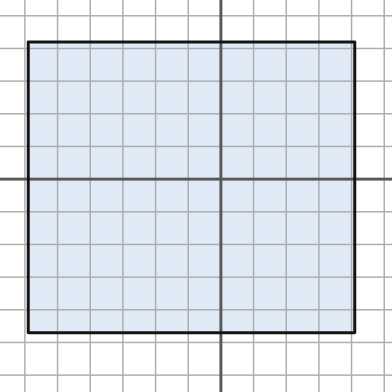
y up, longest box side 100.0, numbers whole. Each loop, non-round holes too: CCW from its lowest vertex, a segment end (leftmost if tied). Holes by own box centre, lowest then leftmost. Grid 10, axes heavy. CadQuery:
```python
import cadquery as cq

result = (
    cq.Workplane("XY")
    .moveTo(-59.0, -47.0)
    .lineTo(41.0, -47.0)
    .lineTo(41.0, 42.0)
    .lineTo(-59.0, 42.0)
    .close()
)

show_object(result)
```